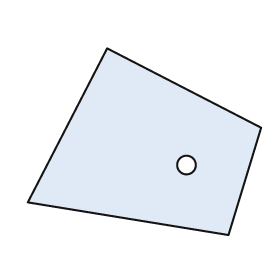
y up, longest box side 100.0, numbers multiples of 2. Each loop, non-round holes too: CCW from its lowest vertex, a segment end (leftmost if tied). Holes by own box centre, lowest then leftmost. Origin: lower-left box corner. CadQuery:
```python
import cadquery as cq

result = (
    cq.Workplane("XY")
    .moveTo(86.0, 0.0)
    .lineTo(100.0, 46.0)
    .lineTo(34.0, 80.0)
    .lineTo(0.0, 14.0)
    .close()
    .moveTo(68.0, 30.0)
    .circle(4.0)
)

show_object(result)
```